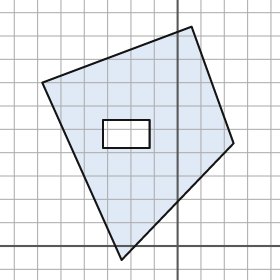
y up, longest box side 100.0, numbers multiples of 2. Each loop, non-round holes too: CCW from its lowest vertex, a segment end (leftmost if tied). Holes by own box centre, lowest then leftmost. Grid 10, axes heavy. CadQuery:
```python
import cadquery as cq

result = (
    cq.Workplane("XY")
    .moveTo(-24.0, -6.0)
    .lineTo(24.0, 44.0)
    .lineTo(6.0, 94.0)
    .lineTo(-58.0, 70.0)
    .close()
    .moveTo(-32.0, 42.0)
    .lineTo(-12.0, 42.0)
    .lineTo(-12.0, 54.0)
    .lineTo(-32.0, 54.0)
    .close()
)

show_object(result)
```